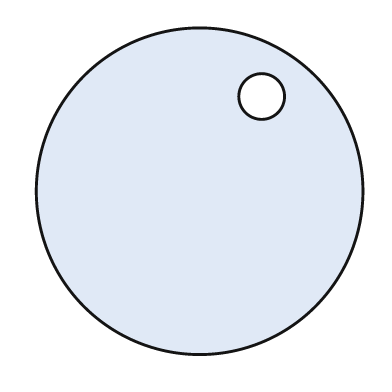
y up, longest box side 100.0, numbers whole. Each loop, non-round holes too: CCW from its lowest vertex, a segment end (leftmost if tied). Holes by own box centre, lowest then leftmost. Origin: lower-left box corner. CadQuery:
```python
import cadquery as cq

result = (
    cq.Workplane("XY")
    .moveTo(50.0, 50.0)
    .circle(50.0)
    .moveTo(69.0, 79.0)
    .circle(7.0)
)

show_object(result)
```